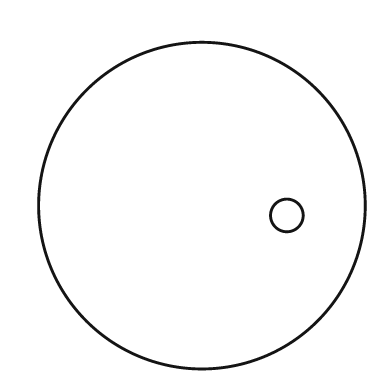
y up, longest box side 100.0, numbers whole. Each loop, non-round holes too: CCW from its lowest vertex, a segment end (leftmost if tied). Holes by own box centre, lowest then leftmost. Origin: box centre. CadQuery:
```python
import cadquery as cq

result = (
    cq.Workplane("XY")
    .moveTo(0.0, 0.0)
    .circle(50.0)
    .moveTo(26.0, -3.0)
    .circle(5.0)
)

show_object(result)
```